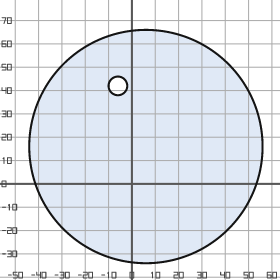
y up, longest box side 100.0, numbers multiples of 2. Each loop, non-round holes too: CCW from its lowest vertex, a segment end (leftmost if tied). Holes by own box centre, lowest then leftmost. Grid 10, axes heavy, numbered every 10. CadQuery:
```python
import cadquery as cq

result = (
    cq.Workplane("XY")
    .moveTo(6.0, 16.0)
    .circle(50.0)
    .moveTo(-6.0, 42.0)
    .circle(4.0)
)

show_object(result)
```